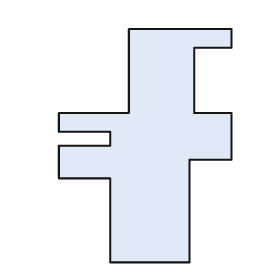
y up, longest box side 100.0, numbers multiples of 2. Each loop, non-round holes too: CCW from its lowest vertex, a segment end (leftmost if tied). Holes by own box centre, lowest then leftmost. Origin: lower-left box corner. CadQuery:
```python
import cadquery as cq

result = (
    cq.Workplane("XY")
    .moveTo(22.0, 0.0)
    .lineTo(56.0, 0.0)
    .lineTo(56.0, 44.0)
    .lineTo(74.0, 44.0)
    .lineTo(74.0, 64.0)
    .lineTo(58.0, 64.0)
    .lineTo(58.0, 92.0)
    .lineTo(74.0, 92.0)
    .lineTo(74.0, 100.0)
    .lineTo(30.0, 100.0)
    .lineTo(30.0, 64.0)
    .lineTo(0.0, 64.0)
    .lineTo(0.0, 56.0)
    .lineTo(22.0, 56.0)
    .lineTo(22.0, 50.0)
    .lineTo(0.0, 50.0)
    .lineTo(0.0, 36.0)
    .lineTo(22.0, 36.0)
    .close()
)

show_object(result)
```